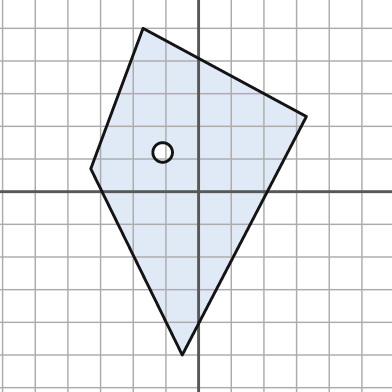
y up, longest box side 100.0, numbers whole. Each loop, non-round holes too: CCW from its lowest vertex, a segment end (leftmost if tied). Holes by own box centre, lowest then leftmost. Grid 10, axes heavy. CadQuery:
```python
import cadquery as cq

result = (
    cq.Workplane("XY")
    .moveTo(-5.0, -50.0)
    .lineTo(33.0, 23.0)
    .lineTo(-17.0, 50.0)
    .lineTo(-33.0, 7.0)
    .close()
    .moveTo(-11.0, 12.0)
    .circle(3.0)
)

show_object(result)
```